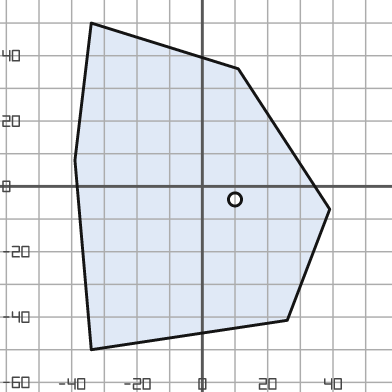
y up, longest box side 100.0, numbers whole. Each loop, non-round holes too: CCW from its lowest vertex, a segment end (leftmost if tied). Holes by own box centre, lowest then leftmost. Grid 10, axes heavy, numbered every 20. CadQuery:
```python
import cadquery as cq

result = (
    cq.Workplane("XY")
    .moveTo(-34.0, -50.0)
    .lineTo(26.0, -41.0)
    .lineTo(39.0, -7.0)
    .lineTo(11.0, 36.0)
    .lineTo(-34.0, 50.0)
    .lineTo(-39.0, 8.0)
    .close()
    .moveTo(10.0, -4.0)
    .circle(2.0)
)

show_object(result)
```